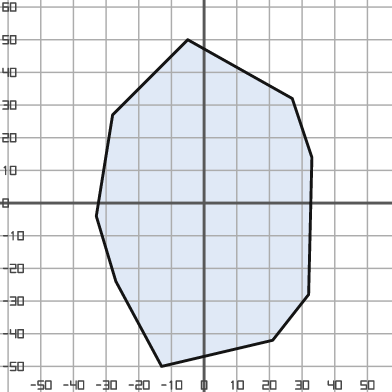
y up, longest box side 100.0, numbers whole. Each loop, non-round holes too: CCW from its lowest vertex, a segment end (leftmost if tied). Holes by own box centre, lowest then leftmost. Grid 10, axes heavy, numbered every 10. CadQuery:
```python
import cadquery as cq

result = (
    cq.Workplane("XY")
    .moveTo(-13.0, -50.0)
    .lineTo(21.0, -42.0)
    .lineTo(32.0, -28.0)
    .lineTo(33.0, 14.0)
    .lineTo(27.0, 32.0)
    .lineTo(-5.0, 50.0)
    .lineTo(-28.0, 27.0)
    .lineTo(-33.0, -4.0)
    .lineTo(-27.0, -24.0)
    .close()
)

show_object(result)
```